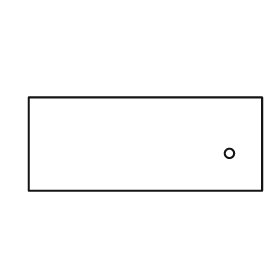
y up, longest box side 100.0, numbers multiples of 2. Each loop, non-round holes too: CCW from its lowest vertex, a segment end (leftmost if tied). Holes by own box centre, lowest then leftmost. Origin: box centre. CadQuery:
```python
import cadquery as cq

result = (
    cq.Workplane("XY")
    .moveTo(-50.0, -20.0)
    .lineTo(50.0, -20.0)
    .lineTo(50.0, 20.0)
    .lineTo(-50.0, 20.0)
    .close()
    .moveTo(36.0, -4.0)
    .circle(2.0)
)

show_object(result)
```